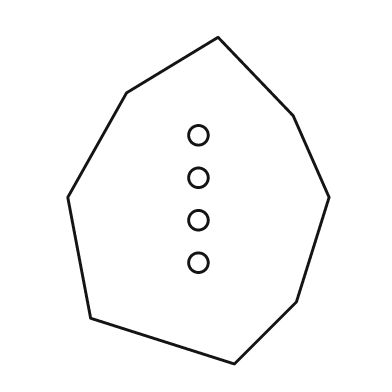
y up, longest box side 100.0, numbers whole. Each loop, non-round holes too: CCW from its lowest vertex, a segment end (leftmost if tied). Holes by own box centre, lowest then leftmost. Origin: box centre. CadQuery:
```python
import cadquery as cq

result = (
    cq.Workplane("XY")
    .moveTo(11.0, -50.0)
    .lineTo(30.0, -31.0)
    .lineTo(40.0, 1.0)
    .lineTo(29.0, 26.0)
    .lineTo(6.0, 50.0)
    .lineTo(-22.0, 33.0)
    .lineTo(-40.0, 1.0)
    .lineTo(-33.0, -36.0)
    .close()
    .moveTo(0.0, -19.0)
    .circle(3.0)
    .moveTo(0.0, -6.0)
    .circle(3.0)
    .moveTo(0.0, 7.0)
    .circle(3.0)
    .moveTo(0.0, 20.0)
    .circle(3.0)
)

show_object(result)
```